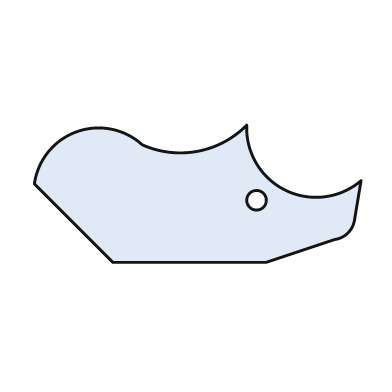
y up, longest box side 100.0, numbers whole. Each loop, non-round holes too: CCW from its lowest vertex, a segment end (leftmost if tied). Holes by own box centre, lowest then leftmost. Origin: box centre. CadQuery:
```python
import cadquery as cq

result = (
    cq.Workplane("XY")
    .moveTo(-26.0, -21.0)
    .lineTo(21.0, -21.0)
    .lineTo(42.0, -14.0)
    .threePointArc((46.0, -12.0), (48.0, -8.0))
    .lineTo(50.0, 4.0)
    .threePointArc((27.0, 1.0), (15.0, 21.0))
    .threePointArc((0.0, 13.0), (-17.0, 15.0))
    .threePointArc((-37.0, 19.0), (-50.0, 3.0))
    .close()
    .moveTo(18.0, -2.0)
    .circle(3.0)
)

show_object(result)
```